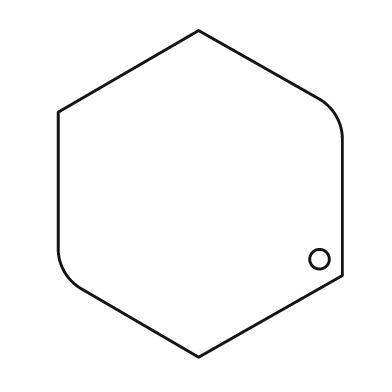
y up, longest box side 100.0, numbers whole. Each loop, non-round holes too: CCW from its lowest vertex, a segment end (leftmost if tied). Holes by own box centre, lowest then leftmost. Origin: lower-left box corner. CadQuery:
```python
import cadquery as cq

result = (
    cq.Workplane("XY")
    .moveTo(43.0, 0.0)
    .lineTo(87.0, 25.0)
    .lineTo(87.0, 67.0)
    .threePointArc((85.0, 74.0), (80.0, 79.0))
    .lineTo(43.0, 100.0)
    .lineTo(0.0, 75.0)
    .lineTo(0.0, 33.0)
    .threePointArc((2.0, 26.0), (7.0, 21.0))
    .close()
    .moveTo(80.0, 30.0)
    .circle(3.0)
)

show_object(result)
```